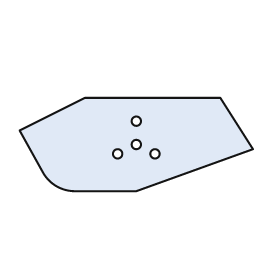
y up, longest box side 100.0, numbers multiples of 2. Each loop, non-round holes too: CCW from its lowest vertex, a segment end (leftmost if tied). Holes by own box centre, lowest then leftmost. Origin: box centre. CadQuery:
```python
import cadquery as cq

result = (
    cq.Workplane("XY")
    .moveTo(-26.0, -20.0)
    .lineTo(0.0, -20.0)
    .lineTo(50.0, -2.0)
    .lineTo(36.0, 20.0)
    .lineTo(-22.0, 20.0)
    .lineTo(-50.0, 6.0)
    .lineTo(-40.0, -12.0)
    .threePointArc((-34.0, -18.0), (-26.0, -20.0))
    .close()
    .moveTo(-8.0, -4.0)
    .circle(2.0)
    .moveTo(8.0, -4.0)
    .circle(2.0)
    .moveTo(0.0, 0.0)
    .circle(2.0)
    .moveTo(0.0, 10.0)
    .circle(2.0)
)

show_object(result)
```